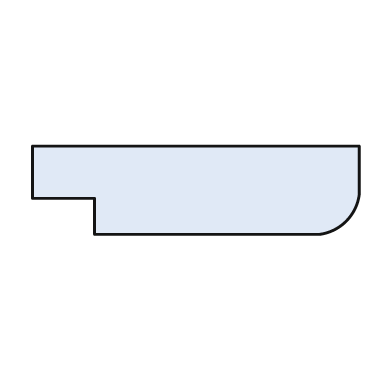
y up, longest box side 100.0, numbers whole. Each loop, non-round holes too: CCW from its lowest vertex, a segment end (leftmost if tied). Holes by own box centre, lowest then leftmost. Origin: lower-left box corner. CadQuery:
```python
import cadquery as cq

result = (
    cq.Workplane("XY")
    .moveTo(19.0, 0.0)
    .lineTo(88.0, 0.0)
    .threePointArc((96.0, 4.0), (100.0, 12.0))
    .lineTo(100.0, 27.0)
    .lineTo(0.0, 27.0)
    .lineTo(0.0, 11.0)
    .lineTo(19.0, 11.0)
    .close()
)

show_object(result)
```